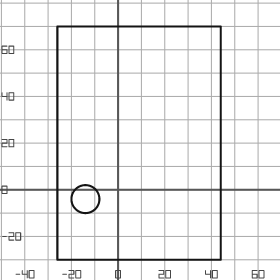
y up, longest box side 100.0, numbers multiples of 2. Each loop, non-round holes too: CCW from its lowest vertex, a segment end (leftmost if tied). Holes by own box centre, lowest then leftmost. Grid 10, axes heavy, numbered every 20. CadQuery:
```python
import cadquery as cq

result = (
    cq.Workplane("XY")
    .moveTo(-26.0, -30.0)
    .lineTo(44.0, -30.0)
    .lineTo(44.0, 70.0)
    .lineTo(-26.0, 70.0)
    .close()
    .moveTo(-14.0, -4.0)
    .circle(6.0)
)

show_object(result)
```